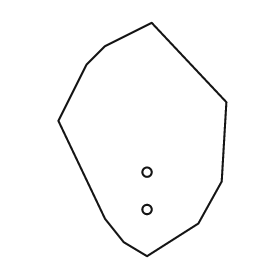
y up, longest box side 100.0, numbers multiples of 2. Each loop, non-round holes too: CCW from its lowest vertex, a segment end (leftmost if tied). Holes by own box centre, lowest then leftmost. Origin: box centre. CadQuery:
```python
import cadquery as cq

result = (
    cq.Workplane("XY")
    .moveTo(2.0, -50.0)
    .lineTo(24.0, -36.0)
    .lineTo(34.0, -18.0)
    .lineTo(36.0, 16.0)
    .lineTo(4.0, 50.0)
    .lineTo(-16.0, 40.0)
    .lineTo(-24.0, 32.0)
    .lineTo(-36.0, 8.0)
    .lineTo(-16.0, -34.0)
    .lineTo(-8.0, -44.0)
    .close()
    .moveTo(2.0, -30.0)
    .circle(2.0)
    .moveTo(2.0, -14.0)
    .circle(2.0)
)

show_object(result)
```